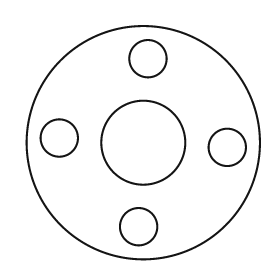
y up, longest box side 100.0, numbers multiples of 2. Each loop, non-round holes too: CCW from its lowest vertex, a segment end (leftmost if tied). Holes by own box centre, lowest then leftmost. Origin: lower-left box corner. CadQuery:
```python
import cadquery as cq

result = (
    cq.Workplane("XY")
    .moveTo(50.0, 50.0)
    .circle(50.0)
    .moveTo(48.0, 14.0)
    .circle(8.0)
    .moveTo(86.0, 48.0)
    .circle(8.0)
    .moveTo(50.0, 50.0)
    .circle(18.0)
    .moveTo(14.0, 52.0)
    .circle(8.0)
    .moveTo(52.0, 86.0)
    .circle(8.0)
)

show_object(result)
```